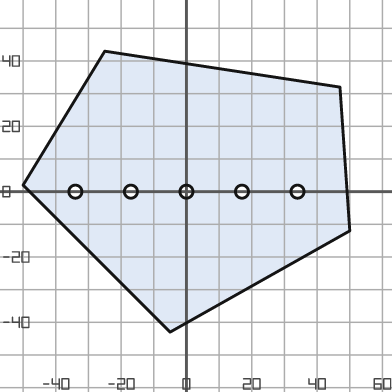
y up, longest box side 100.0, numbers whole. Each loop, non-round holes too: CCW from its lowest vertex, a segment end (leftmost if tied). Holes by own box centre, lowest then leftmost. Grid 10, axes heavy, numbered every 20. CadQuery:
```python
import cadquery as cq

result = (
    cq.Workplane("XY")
    .moveTo(-5.0, -43.0)
    .lineTo(50.0, -12.0)
    .lineTo(47.0, 32.0)
    .lineTo(-25.0, 43.0)
    .lineTo(-50.0, 2.0)
    .close()
    .moveTo(-34.0, 0.0)
    .circle(2.0)
    .moveTo(-17.0, 0.0)
    .circle(2.0)
    .moveTo(0.0, 0.0)
    .circle(2.0)
    .moveTo(17.0, 0.0)
    .circle(2.0)
    .moveTo(34.0, 0.0)
    .circle(2.0)
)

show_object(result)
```